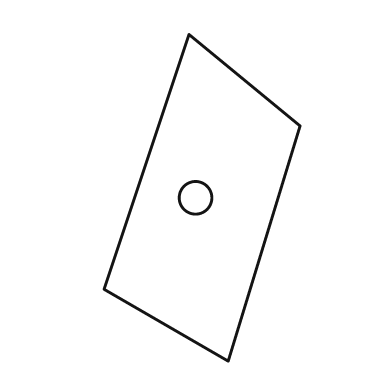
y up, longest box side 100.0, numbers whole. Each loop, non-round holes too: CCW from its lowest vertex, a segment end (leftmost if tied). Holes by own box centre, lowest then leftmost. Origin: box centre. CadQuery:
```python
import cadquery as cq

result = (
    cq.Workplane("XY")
    .moveTo(8.0, -50.0)
    .lineTo(30.0, 22.0)
    .lineTo(-4.0, 50.0)
    .lineTo(-30.0, -28.0)
    .close()
    .moveTo(-2.0, 0.0)
    .circle(5.0)
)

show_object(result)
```